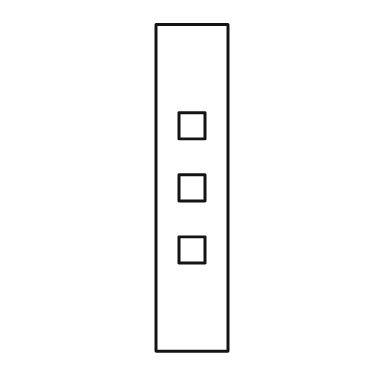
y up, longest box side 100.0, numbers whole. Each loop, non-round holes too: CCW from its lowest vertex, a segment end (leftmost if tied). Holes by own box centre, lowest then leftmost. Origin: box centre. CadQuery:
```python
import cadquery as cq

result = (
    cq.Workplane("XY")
    .moveTo(-11.0, -50.0)
    .lineTo(11.0, -50.0)
    .lineTo(11.0, 50.0)
    .lineTo(-11.0, 50.0)
    .close()
    .moveTo(-4.0, -23.0)
    .lineTo(4.0, -23.0)
    .lineTo(4.0, -15.0)
    .lineTo(-4.0, -15.0)
    .close()
    .moveTo(-4.0, -4.0)
    .lineTo(4.0, -4.0)
    .lineTo(4.0, 4.0)
    .lineTo(-4.0, 4.0)
    .close()
    .moveTo(-4.0, 15.0)
    .lineTo(4.0, 15.0)
    .lineTo(4.0, 23.0)
    .lineTo(-4.0, 23.0)
    .close()
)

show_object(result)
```